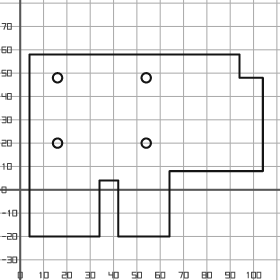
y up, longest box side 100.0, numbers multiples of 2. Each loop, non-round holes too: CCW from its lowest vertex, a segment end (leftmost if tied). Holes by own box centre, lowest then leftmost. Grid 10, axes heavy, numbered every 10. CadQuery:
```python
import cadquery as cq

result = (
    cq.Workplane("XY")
    .moveTo(4.0, -20.0)
    .lineTo(34.0, -20.0)
    .lineTo(34.0, 4.0)
    .lineTo(42.0, 4.0)
    .lineTo(42.0, -20.0)
    .lineTo(64.0, -20.0)
    .lineTo(64.0, 8.0)
    .lineTo(104.0, 8.0)
    .lineTo(104.0, 48.0)
    .lineTo(94.0, 48.0)
    .lineTo(94.0, 58.0)
    .lineTo(4.0, 58.0)
    .close()
    .moveTo(16.0, 20.0)
    .circle(2.0)
    .moveTo(54.0, 20.0)
    .circle(2.0)
    .moveTo(16.0, 48.0)
    .circle(2.0)
    .moveTo(54.0, 48.0)
    .circle(2.0)
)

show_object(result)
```